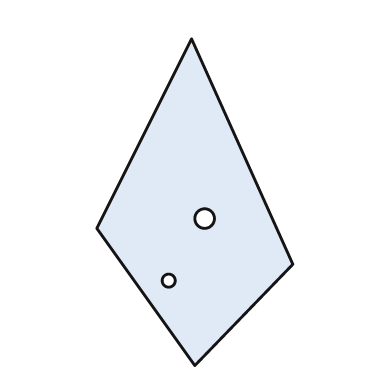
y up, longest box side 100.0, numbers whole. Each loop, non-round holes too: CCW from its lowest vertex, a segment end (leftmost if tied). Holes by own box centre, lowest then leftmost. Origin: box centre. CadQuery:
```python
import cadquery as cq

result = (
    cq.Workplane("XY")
    .moveTo(0.0, -50.0)
    .lineTo(30.0, -19.0)
    .lineTo(-1.0, 50.0)
    .lineTo(-30.0, -8.0)
    .close()
    .moveTo(-8.0, -24.0)
    .circle(2.0)
    .moveTo(3.0, -5.0)
    .circle(3.0)
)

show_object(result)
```